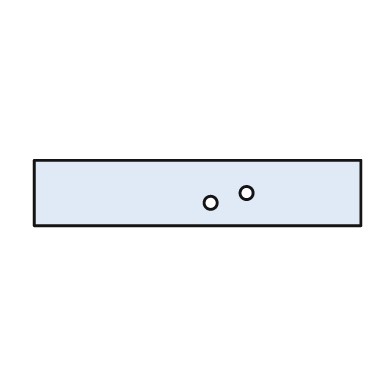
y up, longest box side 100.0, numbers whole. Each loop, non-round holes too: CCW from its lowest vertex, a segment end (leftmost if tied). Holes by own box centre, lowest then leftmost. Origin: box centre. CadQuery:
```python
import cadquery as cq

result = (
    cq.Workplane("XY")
    .moveTo(-50.0, -10.0)
    .lineTo(50.0, -10.0)
    .lineTo(50.0, 10.0)
    .lineTo(-50.0, 10.0)
    .close()
    .moveTo(4.0, -3.0)
    .circle(2.0)
    .moveTo(15.0, 0.0)
    .circle(2.0)
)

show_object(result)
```